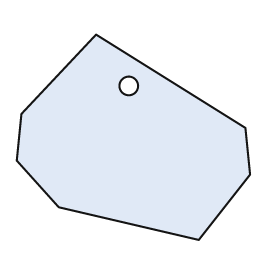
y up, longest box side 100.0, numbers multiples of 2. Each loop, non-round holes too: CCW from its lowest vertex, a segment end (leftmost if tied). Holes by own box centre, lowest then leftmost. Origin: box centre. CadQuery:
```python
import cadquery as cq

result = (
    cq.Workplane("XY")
    .moveTo(28.0, -44.0)
    .lineTo(50.0, -16.0)
    .lineTo(48.0, 4.0)
    .lineTo(-16.0, 44.0)
    .lineTo(-48.0, 10.0)
    .lineTo(-50.0, -10.0)
    .lineTo(-32.0, -30.0)
    .close()
    .moveTo(-2.0, 22.0)
    .circle(4.0)
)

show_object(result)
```